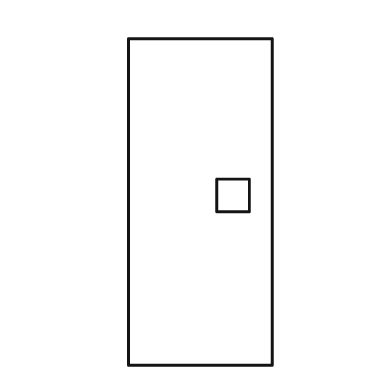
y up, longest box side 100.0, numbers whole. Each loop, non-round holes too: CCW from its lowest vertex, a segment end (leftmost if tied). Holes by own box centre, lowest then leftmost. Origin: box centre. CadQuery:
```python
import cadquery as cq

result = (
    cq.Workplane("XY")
    .moveTo(-22.0, -50.0)
    .lineTo(22.0, -50.0)
    .lineTo(22.0, 50.0)
    .lineTo(-22.0, 50.0)
    .close()
    .moveTo(5.0, -3.0)
    .lineTo(15.0, -3.0)
    .lineTo(15.0, 7.0)
    .lineTo(5.0, 7.0)
    .close()
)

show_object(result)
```